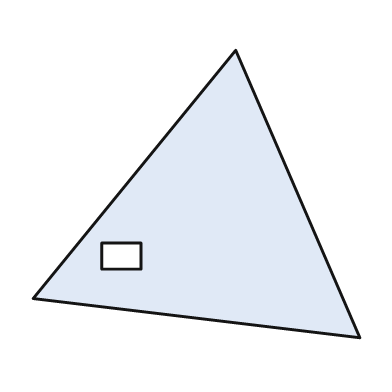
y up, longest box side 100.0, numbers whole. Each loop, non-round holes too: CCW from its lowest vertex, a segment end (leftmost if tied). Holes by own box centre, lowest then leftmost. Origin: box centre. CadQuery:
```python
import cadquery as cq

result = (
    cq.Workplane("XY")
    .moveTo(50.0, -44.0)
    .lineTo(12.0, 44.0)
    .lineTo(-50.0, -32.0)
    .close()
    .moveTo(-29.0, -23.0)
    .lineTo(-17.0, -23.0)
    .lineTo(-17.0, -15.0)
    .lineTo(-29.0, -15.0)
    .close()
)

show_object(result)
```